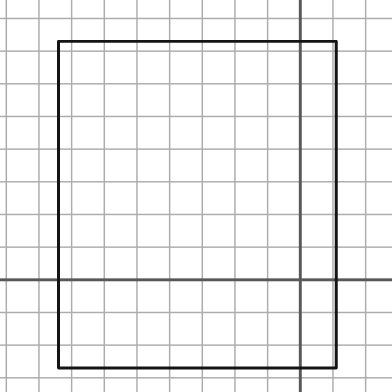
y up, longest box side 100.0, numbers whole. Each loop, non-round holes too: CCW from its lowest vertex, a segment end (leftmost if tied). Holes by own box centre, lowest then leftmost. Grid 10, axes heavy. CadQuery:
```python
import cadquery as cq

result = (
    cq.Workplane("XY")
    .moveTo(-74.0, -27.0)
    .lineTo(11.0, -27.0)
    .lineTo(11.0, 73.0)
    .lineTo(-74.0, 73.0)
    .close()
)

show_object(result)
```